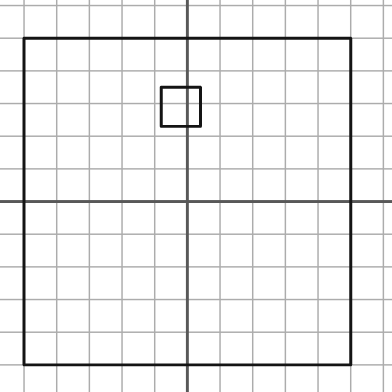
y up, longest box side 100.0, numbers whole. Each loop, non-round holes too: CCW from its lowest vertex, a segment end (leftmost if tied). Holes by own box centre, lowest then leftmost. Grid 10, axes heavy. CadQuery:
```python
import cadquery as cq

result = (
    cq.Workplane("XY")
    .moveTo(-50.0, -50.0)
    .lineTo(50.0, -50.0)
    .lineTo(50.0, 50.0)
    .lineTo(-50.0, 50.0)
    .close()
    .moveTo(-8.0, 23.0)
    .lineTo(4.0, 23.0)
    .lineTo(4.0, 35.0)
    .lineTo(-8.0, 35.0)
    .close()
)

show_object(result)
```